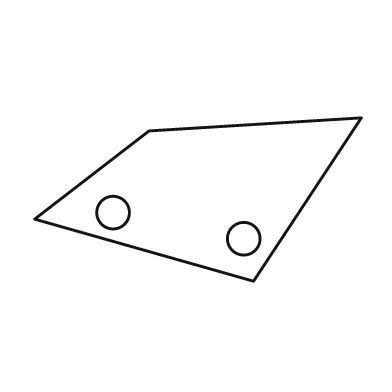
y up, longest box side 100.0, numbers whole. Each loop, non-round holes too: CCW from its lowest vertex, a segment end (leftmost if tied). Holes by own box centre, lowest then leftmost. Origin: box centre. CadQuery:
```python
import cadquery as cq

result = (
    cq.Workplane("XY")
    .moveTo(17.0, -25.0)
    .lineTo(50.0, 25.0)
    .lineTo(-15.0, 21.0)
    .lineTo(-50.0, -6.0)
    .close()
    .moveTo(14.0, -12.0)
    .circle(5.0)
    .moveTo(-26.0, -4.0)
    .circle(5.0)
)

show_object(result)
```